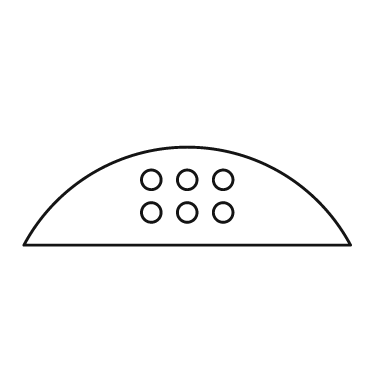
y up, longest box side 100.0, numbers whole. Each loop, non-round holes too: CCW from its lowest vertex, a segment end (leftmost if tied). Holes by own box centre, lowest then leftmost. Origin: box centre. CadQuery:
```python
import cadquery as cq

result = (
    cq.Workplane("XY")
    .moveTo(-50.0, -15.0)
    .lineTo(50.0, -15.0)
    .threePointArc((0.0, 15.0), (-50.0, -15.0))
    .close()
    .moveTo(-11.0, -5.0)
    .circle(3.0)
    .moveTo(0.0, -5.0)
    .circle(3.0)
    .moveTo(11.0, -5.0)
    .circle(3.0)
    .moveTo(-11.0, 5.0)
    .circle(3.0)
    .moveTo(0.0, 5.0)
    .circle(3.0)
    .moveTo(11.0, 5.0)
    .circle(3.0)
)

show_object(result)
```